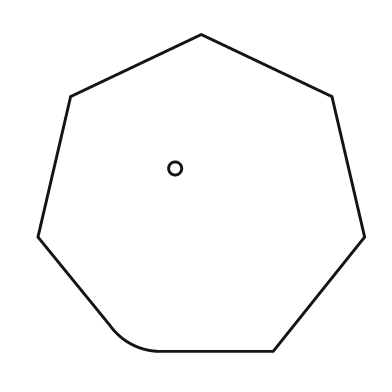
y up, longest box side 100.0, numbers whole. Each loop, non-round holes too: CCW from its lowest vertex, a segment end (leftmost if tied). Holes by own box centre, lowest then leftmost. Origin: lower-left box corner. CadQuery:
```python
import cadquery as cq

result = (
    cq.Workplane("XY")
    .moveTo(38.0, 0.0)
    .lineTo(72.0, 0.0)
    .lineTo(100.0, 35.0)
    .lineTo(90.0, 78.0)
    .lineTo(50.0, 97.0)
    .lineTo(10.0, 78.0)
    .lineTo(0.0, 35.0)
    .lineTo(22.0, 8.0)
    .threePointArc((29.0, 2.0), (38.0, 0.0))
    .close()
    .moveTo(42.0, 56.0)
    .circle(2.0)
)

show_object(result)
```